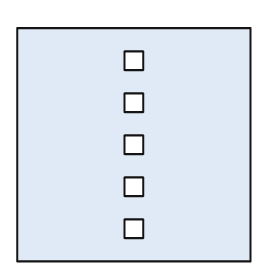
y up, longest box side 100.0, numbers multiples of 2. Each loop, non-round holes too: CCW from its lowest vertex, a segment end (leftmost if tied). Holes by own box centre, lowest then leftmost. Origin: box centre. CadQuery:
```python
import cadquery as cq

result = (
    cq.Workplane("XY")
    .moveTo(-50.0, -50.0)
    .lineTo(50.0, -50.0)
    .lineTo(50.0, 50.0)
    .lineTo(-50.0, 50.0)
    .close()
    .moveTo(-4.0, -40.0)
    .lineTo(4.0, -40.0)
    .lineTo(4.0, -32.0)
    .lineTo(-4.0, -32.0)
    .close()
    .moveTo(-4.0, -22.0)
    .lineTo(4.0, -22.0)
    .lineTo(4.0, -14.0)
    .lineTo(-4.0, -14.0)
    .close()
    .moveTo(-4.0, -4.0)
    .lineTo(4.0, -4.0)
    .lineTo(4.0, 4.0)
    .lineTo(-4.0, 4.0)
    .close()
    .moveTo(-4.0, 14.0)
    .lineTo(4.0, 14.0)
    .lineTo(4.0, 22.0)
    .lineTo(-4.0, 22.0)
    .close()
    .moveTo(-4.0, 32.0)
    .lineTo(4.0, 32.0)
    .lineTo(4.0, 40.0)
    .lineTo(-4.0, 40.0)
    .close()
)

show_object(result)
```